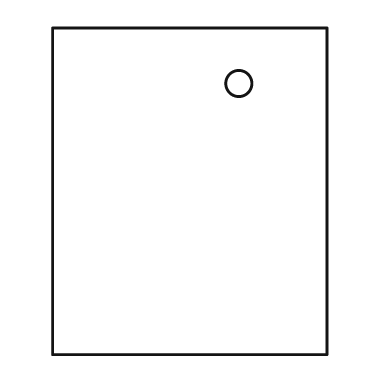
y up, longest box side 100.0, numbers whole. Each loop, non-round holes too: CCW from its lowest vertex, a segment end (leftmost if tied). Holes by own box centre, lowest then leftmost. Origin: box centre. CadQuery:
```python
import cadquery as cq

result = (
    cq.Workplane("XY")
    .moveTo(-42.0, -50.0)
    .lineTo(42.0, -50.0)
    .lineTo(42.0, 50.0)
    .lineTo(-42.0, 50.0)
    .close()
    .moveTo(15.0, 33.0)
    .circle(4.0)
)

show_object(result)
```